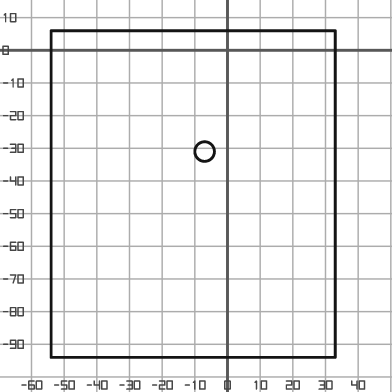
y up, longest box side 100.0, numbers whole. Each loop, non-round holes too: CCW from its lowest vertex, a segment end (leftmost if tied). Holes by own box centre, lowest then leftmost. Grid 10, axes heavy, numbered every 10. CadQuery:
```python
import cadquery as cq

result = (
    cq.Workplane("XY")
    .moveTo(-54.0, -94.0)
    .lineTo(33.0, -94.0)
    .lineTo(33.0, 6.0)
    .lineTo(-54.0, 6.0)
    .close()
    .moveTo(-7.0, -31.0)
    .circle(3.0)
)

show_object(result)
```